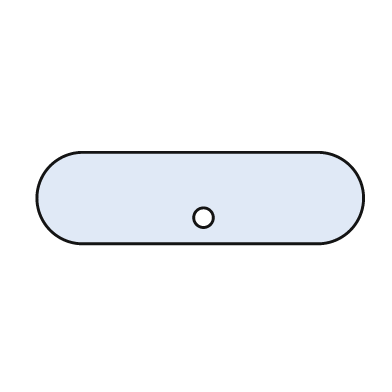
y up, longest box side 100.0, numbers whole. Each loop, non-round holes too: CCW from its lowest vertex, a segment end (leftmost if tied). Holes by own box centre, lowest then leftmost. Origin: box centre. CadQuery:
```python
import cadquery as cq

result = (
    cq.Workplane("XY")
    .moveTo(-36.0, -14.0)
    .lineTo(36.0, -14.0)
    .threePointArc((50.0, 0.0), (36.0, 14.0))
    .lineTo(-36.0, 14.0)
    .threePointArc((-50.0, 0.0), (-36.0, -14.0))
    .close()
    .moveTo(1.0, -6.0)
    .circle(3.0)
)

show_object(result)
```